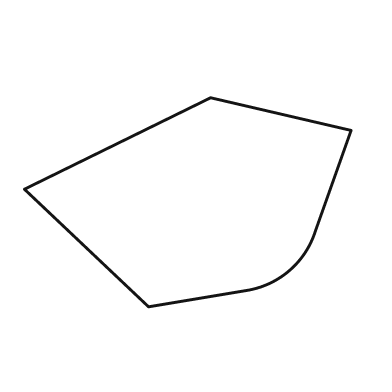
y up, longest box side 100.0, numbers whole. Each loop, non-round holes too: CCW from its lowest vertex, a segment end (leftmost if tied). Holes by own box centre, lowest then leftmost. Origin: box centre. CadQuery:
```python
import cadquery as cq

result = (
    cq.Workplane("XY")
    .moveTo(-12.0, -32.0)
    .lineTo(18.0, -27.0)
    .threePointArc((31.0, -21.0), (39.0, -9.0))
    .lineTo(50.0, 22.0)
    .lineTo(7.0, 32.0)
    .lineTo(-50.0, 4.0)
    .close()
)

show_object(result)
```